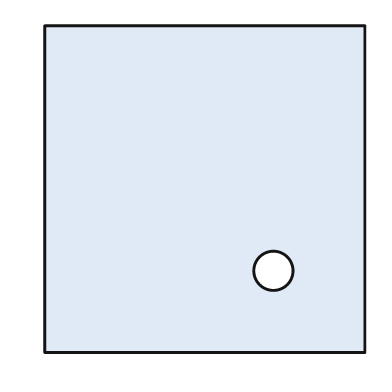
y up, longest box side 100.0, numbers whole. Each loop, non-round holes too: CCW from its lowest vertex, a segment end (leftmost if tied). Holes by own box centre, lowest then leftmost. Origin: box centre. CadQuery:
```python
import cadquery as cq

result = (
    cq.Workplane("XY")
    .moveTo(-49.0, -50.0)
    .lineTo(49.0, -50.0)
    .lineTo(49.0, 50.0)
    .lineTo(-49.0, 50.0)
    .close()
    .moveTo(21.0, -25.0)
    .circle(6.0)
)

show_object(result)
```